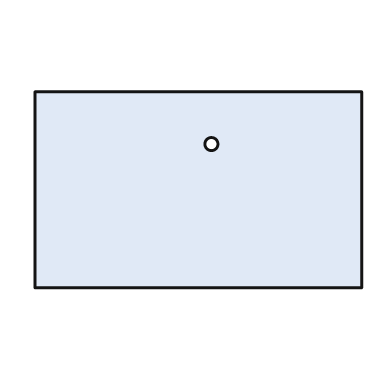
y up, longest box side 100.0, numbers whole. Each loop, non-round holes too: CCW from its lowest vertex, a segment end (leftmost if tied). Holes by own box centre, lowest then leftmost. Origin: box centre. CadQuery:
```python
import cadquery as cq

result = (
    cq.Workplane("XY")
    .moveTo(-50.0, -30.0)
    .lineTo(50.0, -30.0)
    .lineTo(50.0, 30.0)
    .lineTo(-50.0, 30.0)
    .close()
    .moveTo(4.0, 14.0)
    .circle(2.0)
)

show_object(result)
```